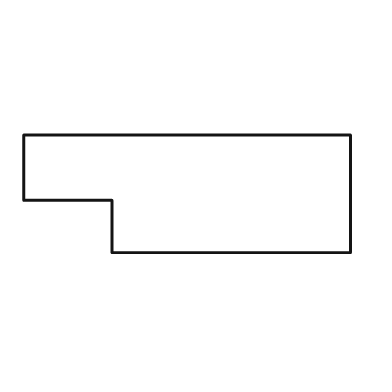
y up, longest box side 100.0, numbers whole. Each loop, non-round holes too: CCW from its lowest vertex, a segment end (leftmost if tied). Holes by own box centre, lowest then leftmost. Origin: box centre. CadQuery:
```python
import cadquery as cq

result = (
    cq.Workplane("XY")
    .moveTo(-23.0, -18.0)
    .lineTo(50.0, -18.0)
    .lineTo(50.0, 18.0)
    .lineTo(-50.0, 18.0)
    .lineTo(-50.0, -2.0)
    .lineTo(-23.0, -2.0)
    .close()
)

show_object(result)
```